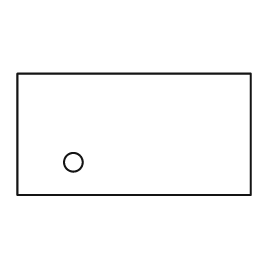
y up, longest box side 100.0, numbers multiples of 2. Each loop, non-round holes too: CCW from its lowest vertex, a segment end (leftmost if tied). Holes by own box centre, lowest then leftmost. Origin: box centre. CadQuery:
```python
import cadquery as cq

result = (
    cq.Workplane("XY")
    .moveTo(-50.0, -26.0)
    .lineTo(50.0, -26.0)
    .lineTo(50.0, 26.0)
    .lineTo(-50.0, 26.0)
    .close()
    .moveTo(-26.0, -12.0)
    .circle(4.0)
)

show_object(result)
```